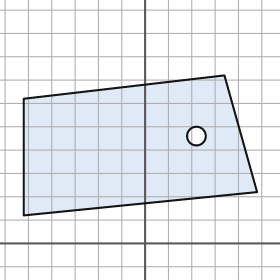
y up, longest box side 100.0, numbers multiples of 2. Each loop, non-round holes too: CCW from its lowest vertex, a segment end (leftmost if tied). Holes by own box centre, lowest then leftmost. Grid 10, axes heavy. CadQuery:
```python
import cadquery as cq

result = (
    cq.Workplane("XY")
    .moveTo(-52.0, 12.0)
    .lineTo(48.0, 22.0)
    .lineTo(34.0, 72.0)
    .lineTo(-52.0, 62.0)
    .close()
    .moveTo(22.0, 46.0)
    .circle(4.0)
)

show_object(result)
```